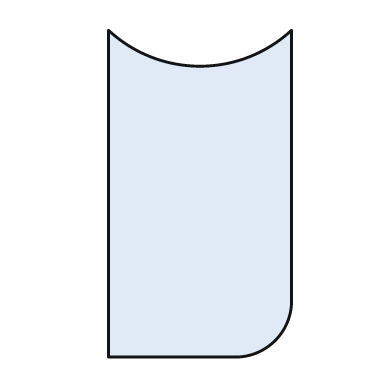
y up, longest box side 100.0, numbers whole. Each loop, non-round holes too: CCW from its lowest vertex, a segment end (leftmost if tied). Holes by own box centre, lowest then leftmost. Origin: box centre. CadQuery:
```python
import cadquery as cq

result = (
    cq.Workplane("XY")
    .moveTo(-28.0, -50.0)
    .lineTo(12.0, -50.0)
    .threePointArc((23.0, -45.0), (28.0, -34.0))
    .lineTo(28.0, 50.0)
    .threePointArc((0.0, 39.0), (-28.0, 50.0))
    .close()
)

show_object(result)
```